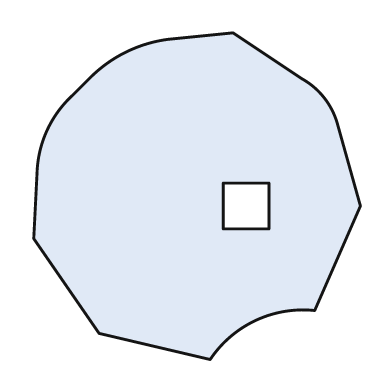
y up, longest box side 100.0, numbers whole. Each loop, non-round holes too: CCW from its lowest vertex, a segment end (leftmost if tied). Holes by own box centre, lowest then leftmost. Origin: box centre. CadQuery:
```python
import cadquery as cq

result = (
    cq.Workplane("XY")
    .moveTo(4.0, -50.0)
    .threePointArc((18.0, -38.0), (36.0, -35.0))
    .lineTo(50.0, -3.0)
    .lineTo(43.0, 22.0)
    .threePointArc((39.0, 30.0), (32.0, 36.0))
    .lineTo(11.0, 50.0)
    .lineTo(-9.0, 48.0)
    .threePointArc((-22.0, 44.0), (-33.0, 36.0))
    .lineTo(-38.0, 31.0)
    .threePointArc((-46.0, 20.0), (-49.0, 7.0))
    .lineTo(-50.0, -13.0)
    .lineTo(-30.0, -42.0)
    .close()
    .moveTo(8.0, -10.0)
    .lineTo(22.0, -10.0)
    .lineTo(22.0, 4.0)
    .lineTo(8.0, 4.0)
    .close()
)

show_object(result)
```